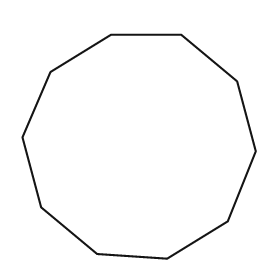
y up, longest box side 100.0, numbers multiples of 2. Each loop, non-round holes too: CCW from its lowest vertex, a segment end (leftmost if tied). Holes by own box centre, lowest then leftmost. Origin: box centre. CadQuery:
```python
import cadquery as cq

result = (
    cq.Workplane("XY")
    .moveTo(12.0, -48.0)
    .lineTo(38.0, -32.0)
    .lineTo(50.0, -2.0)
    .lineTo(42.0, 28.0)
    .lineTo(18.0, 48.0)
    .lineTo(-12.0, 48.0)
    .lineTo(-38.0, 32.0)
    .lineTo(-50.0, 4.0)
    .lineTo(-42.0, -26.0)
    .lineTo(-18.0, -46.0)
    .close()
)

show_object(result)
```